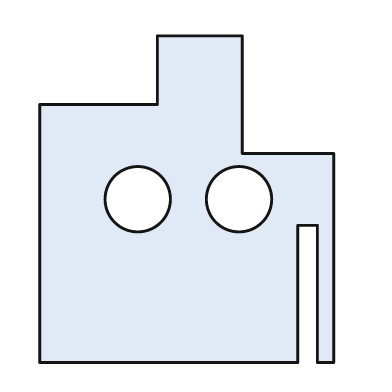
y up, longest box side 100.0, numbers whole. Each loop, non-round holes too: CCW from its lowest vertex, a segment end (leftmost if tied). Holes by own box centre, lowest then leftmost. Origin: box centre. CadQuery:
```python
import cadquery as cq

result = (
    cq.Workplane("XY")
    .moveTo(-45.0, -50.0)
    .lineTo(34.0, -50.0)
    .lineTo(34.0, -8.0)
    .lineTo(40.0, -8.0)
    .lineTo(40.0, -50.0)
    .lineTo(45.0, -50.0)
    .lineTo(45.0, 14.0)
    .lineTo(17.0, 14.0)
    .lineTo(17.0, 50.0)
    .lineTo(-9.0, 50.0)
    .lineTo(-9.0, 29.0)
    .lineTo(-45.0, 29.0)
    .close()
    .moveTo(-15.0, 0.0)
    .circle(10.0)
    .moveTo(16.0, 0.0)
    .circle(10.0)
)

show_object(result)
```